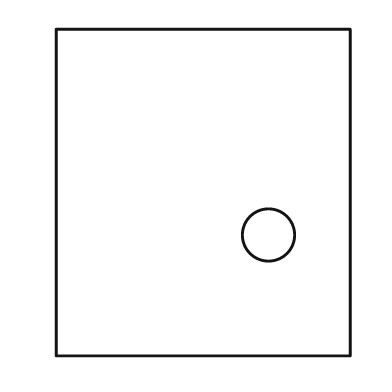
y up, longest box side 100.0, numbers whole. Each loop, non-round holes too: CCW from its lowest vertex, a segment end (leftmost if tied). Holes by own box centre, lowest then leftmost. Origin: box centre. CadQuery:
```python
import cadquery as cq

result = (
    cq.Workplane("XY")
    .moveTo(-45.0, -50.0)
    .lineTo(45.0, -50.0)
    .lineTo(45.0, 50.0)
    .lineTo(-45.0, 50.0)
    .close()
    .moveTo(20.0, -13.0)
    .circle(8.0)
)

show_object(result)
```